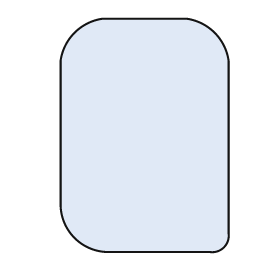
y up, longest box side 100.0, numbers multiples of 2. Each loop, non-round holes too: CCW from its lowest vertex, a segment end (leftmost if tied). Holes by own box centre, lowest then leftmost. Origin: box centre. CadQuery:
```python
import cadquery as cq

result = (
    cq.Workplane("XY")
    .moveTo(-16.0, -50.0)
    .lineTo(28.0, -50.0)
    .threePointArc((34.0, -48.0), (36.0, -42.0))
    .lineTo(36.0, 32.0)
    .threePointArc((30.0, 44.0), (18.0, 50.0))
    .lineTo(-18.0, 50.0)
    .threePointArc((-30.0, 44.0), (-36.0, 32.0))
    .lineTo(-36.0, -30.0)
    .threePointArc((-30.0, -44.0), (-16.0, -50.0))
    .close()
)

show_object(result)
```